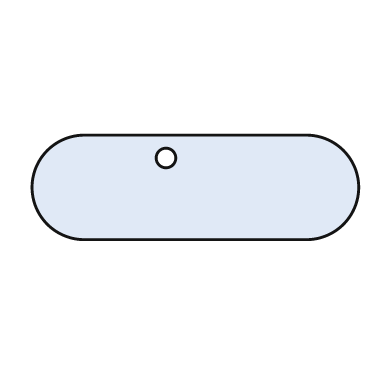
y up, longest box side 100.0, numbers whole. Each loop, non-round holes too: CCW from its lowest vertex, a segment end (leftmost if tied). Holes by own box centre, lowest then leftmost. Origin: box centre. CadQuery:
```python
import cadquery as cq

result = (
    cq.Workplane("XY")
    .moveTo(-34.0, -16.0)
    .lineTo(34.0, -16.0)
    .threePointArc((50.0, 0.0), (34.0, 16.0))
    .lineTo(-34.0, 16.0)
    .threePointArc((-50.0, 0.0), (-34.0, -16.0))
    .close()
    .moveTo(-9.0, 9.0)
    .circle(3.0)
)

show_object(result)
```